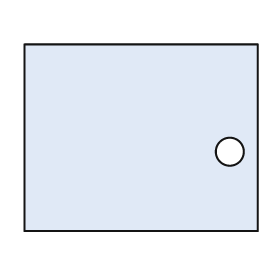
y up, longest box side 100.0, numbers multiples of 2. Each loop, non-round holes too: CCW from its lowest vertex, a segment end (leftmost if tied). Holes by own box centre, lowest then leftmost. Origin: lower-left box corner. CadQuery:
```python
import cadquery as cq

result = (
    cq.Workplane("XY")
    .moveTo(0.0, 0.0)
    .lineTo(100.0, 0.0)
    .lineTo(100.0, 80.0)
    .lineTo(0.0, 80.0)
    .close()
    .moveTo(88.0, 34.0)
    .circle(6.0)
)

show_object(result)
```